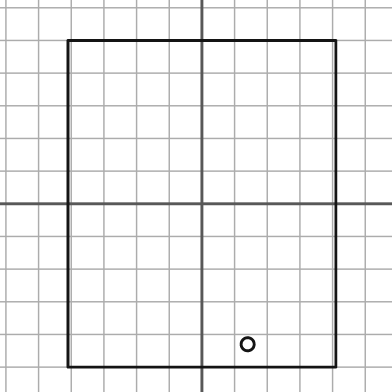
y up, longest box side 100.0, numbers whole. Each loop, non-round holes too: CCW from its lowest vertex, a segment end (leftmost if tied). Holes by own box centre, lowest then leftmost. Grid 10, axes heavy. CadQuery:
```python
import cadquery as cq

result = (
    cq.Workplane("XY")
    .moveTo(-41.0, -50.0)
    .lineTo(41.0, -50.0)
    .lineTo(41.0, 50.0)
    .lineTo(-41.0, 50.0)
    .close()
    .moveTo(14.0, -43.0)
    .circle(2.0)
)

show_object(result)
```